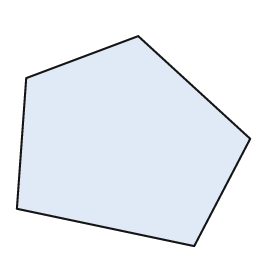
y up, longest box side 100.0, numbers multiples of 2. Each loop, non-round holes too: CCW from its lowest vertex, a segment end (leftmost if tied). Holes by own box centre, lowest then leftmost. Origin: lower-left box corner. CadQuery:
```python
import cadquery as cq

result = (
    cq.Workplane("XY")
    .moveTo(76.0, 0.0)
    .lineTo(100.0, 46.0)
    .lineTo(52.0, 90.0)
    .lineTo(4.0, 72.0)
    .lineTo(0.0, 16.0)
    .close()
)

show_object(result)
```